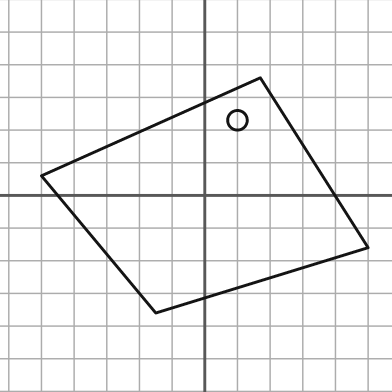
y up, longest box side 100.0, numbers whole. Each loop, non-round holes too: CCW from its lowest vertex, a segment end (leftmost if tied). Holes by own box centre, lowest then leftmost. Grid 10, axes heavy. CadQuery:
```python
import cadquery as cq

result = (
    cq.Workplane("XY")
    .moveTo(-15.0, -36.0)
    .lineTo(50.0, -16.0)
    .lineTo(17.0, 36.0)
    .lineTo(-50.0, 6.0)
    .close()
    .moveTo(10.0, 23.0)
    .circle(3.0)
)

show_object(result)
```